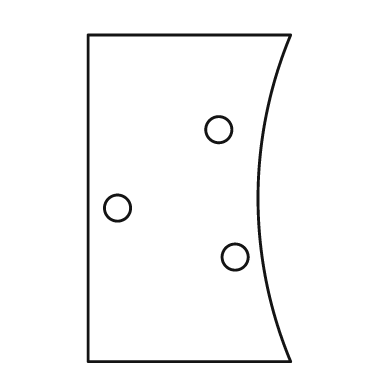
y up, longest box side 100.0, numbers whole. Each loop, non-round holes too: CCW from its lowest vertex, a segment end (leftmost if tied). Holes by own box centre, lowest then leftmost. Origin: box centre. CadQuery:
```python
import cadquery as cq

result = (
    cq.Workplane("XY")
    .moveTo(-31.0, -50.0)
    .lineTo(31.0, -50.0)
    .threePointArc((21.0, 0.0), (31.0, 50.0))
    .lineTo(-31.0, 50.0)
    .close()
    .moveTo(14.0, -18.0)
    .circle(4.0)
    .moveTo(-22.0, -3.0)
    .circle(4.0)
    .moveTo(9.0, 21.0)
    .circle(4.0)
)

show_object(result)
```